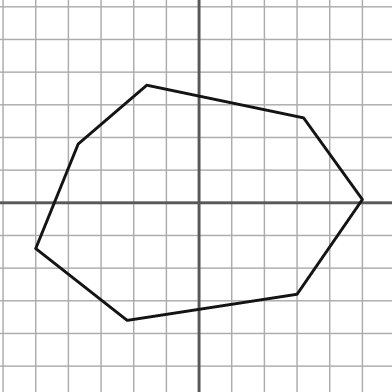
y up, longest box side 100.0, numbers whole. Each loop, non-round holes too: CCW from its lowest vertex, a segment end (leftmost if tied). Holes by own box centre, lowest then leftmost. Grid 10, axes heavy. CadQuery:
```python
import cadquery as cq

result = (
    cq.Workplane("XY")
    .moveTo(-22.0, -36.0)
    .lineTo(30.0, -28.0)
    .lineTo(50.0, 1.0)
    .lineTo(32.0, 26.0)
    .lineTo(-16.0, 36.0)
    .lineTo(-37.0, 18.0)
    .lineTo(-50.0, -14.0)
    .close()
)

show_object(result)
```